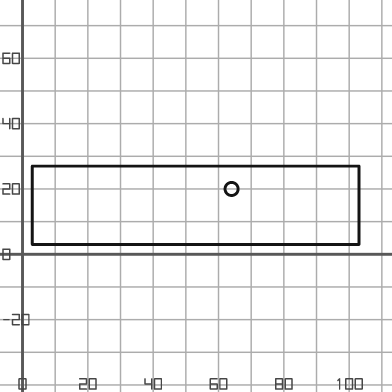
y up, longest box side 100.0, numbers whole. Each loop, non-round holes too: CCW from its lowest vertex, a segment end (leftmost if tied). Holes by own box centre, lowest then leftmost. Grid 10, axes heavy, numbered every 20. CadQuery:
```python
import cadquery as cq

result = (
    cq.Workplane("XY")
    .moveTo(3.0, 3.0)
    .lineTo(103.0, 3.0)
    .lineTo(103.0, 27.0)
    .lineTo(3.0, 27.0)
    .close()
    .moveTo(64.0, 20.0)
    .circle(2.0)
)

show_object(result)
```